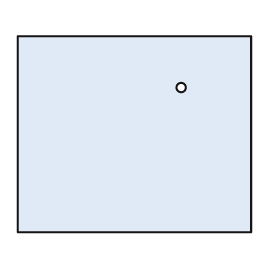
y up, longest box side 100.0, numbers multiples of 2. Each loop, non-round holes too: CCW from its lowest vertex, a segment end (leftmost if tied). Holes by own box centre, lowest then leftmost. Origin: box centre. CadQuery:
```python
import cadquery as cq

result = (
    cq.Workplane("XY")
    .moveTo(-50.0, -42.0)
    .lineTo(50.0, -42.0)
    .lineTo(50.0, 42.0)
    .lineTo(-50.0, 42.0)
    .close()
    .moveTo(20.0, 20.0)
    .circle(2.0)
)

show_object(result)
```